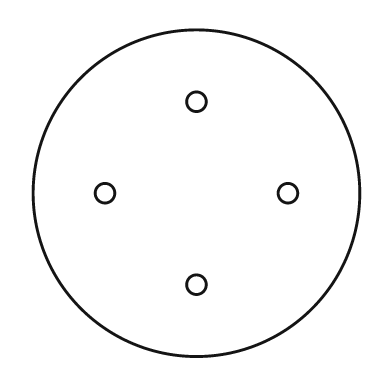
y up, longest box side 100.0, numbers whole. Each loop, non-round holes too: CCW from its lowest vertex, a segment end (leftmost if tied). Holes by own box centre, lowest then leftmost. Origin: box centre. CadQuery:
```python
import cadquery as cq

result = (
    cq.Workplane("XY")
    .moveTo(0.0, 0.0)
    .circle(50.0)
    .moveTo(0.0, -28.0)
    .circle(3.0)
    .moveTo(-28.0, 0.0)
    .circle(3.0)
    .moveTo(28.0, 0.0)
    .circle(3.0)
    .moveTo(0.0, 28.0)
    .circle(3.0)
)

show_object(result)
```